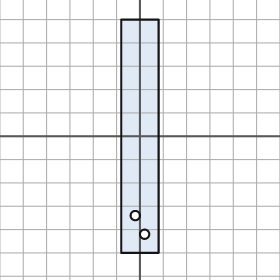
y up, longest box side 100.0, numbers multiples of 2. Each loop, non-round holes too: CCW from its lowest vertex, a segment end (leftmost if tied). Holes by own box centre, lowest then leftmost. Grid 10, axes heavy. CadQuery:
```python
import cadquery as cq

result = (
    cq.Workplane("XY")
    .moveTo(-8.0, -50.0)
    .lineTo(8.0, -50.0)
    .lineTo(8.0, 50.0)
    .lineTo(-8.0, 50.0)
    .close()
    .moveTo(2.0, -42.0)
    .circle(2.0)
    .moveTo(-2.0, -34.0)
    .circle(2.0)
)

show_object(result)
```